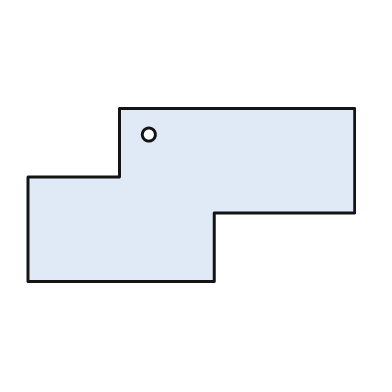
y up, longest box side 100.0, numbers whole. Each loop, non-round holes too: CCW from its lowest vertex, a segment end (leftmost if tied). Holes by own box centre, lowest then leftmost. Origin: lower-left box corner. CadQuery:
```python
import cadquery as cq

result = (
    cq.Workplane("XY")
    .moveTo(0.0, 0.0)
    .lineTo(57.0, 0.0)
    .lineTo(57.0, 21.0)
    .lineTo(100.0, 21.0)
    .lineTo(100.0, 53.0)
    .lineTo(28.0, 53.0)
    .lineTo(28.0, 32.0)
    .lineTo(0.0, 32.0)
    .close()
    .moveTo(37.0, 45.0)
    .circle(2.0)
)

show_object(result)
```